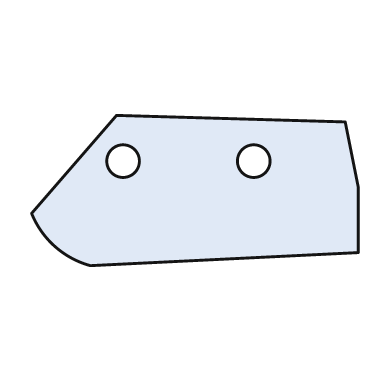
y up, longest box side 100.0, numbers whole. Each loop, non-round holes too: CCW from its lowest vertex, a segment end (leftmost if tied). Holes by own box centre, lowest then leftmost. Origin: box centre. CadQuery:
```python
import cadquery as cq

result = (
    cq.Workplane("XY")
    .moveTo(-32.0, -23.0)
    .lineTo(50.0, -19.0)
    .lineTo(50.0, 1.0)
    .lineTo(46.0, 21.0)
    .lineTo(-24.0, 23.0)
    .lineTo(-50.0, -7.0)
    .threePointArc((-43.0, -17.0), (-32.0, -23.0))
    .close()
    .moveTo(-22.0, 9.0)
    .circle(5.0)
    .moveTo(18.0, 9.0)
    .circle(5.0)
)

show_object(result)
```